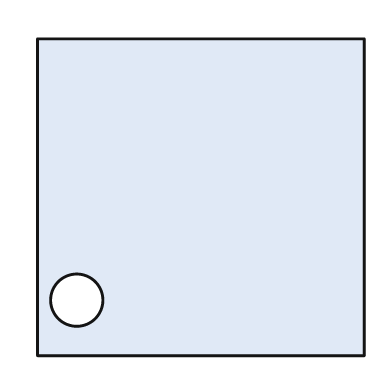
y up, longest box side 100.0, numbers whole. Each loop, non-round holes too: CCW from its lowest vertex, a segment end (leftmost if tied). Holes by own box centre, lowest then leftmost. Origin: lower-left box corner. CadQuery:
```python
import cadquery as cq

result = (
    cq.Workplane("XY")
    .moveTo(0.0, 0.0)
    .lineTo(100.0, 0.0)
    .lineTo(100.0, 97.0)
    .lineTo(0.0, 97.0)
    .close()
    .moveTo(12.0, 17.0)
    .circle(8.0)
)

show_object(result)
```